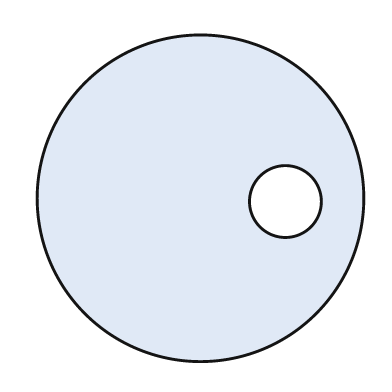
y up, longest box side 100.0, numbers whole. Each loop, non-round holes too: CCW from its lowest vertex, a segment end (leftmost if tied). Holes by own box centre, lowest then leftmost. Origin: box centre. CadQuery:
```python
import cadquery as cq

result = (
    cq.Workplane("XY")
    .moveTo(0.0, 0.0)
    .circle(50.0)
    .moveTo(26.0, -1.0)
    .circle(11.0)
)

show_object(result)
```